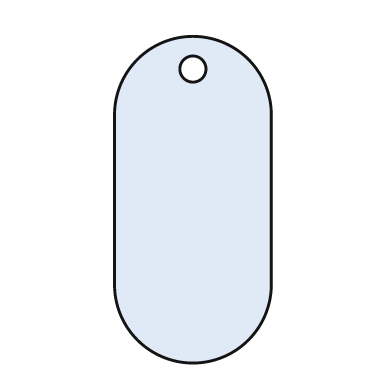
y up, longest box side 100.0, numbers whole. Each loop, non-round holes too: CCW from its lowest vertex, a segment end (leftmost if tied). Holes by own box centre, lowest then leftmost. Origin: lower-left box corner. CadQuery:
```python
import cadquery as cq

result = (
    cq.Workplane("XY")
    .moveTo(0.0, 24.0)
    .threePointArc((24.0, 0.0), (48.0, 24.0))
    .lineTo(48.0, 76.0)
    .threePointArc((24.0, 100.0), (0.0, 76.0))
    .close()
    .moveTo(24.0, 90.0)
    .circle(4.0)
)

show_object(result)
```